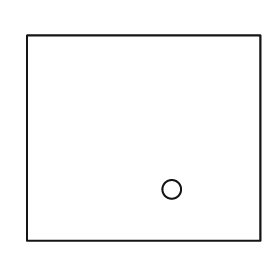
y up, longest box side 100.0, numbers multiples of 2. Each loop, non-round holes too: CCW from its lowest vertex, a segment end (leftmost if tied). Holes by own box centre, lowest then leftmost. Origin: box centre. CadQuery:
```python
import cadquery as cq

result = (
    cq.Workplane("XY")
    .moveTo(-50.0, -44.0)
    .lineTo(50.0, -44.0)
    .lineTo(50.0, 44.0)
    .lineTo(-50.0, 44.0)
    .close()
    .moveTo(12.0, -22.0)
    .circle(4.0)
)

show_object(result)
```